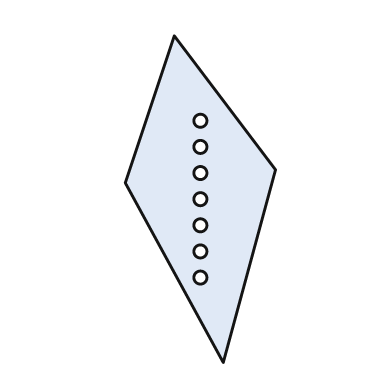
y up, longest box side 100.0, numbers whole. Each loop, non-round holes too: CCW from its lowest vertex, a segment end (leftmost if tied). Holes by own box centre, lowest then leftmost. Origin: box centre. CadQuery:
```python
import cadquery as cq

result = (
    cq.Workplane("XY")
    .moveTo(7.0, -50.0)
    .lineTo(23.0, 9.0)
    .lineTo(-8.0, 50.0)
    .lineTo(-23.0, 5.0)
    .close()
    .moveTo(0.0, -24.0)
    .circle(2.0)
    .moveTo(0.0, -16.0)
    .circle(2.0)
    .moveTo(0.0, -8.0)
    .circle(2.0)
    .moveTo(0.0, 0.0)
    .circle(2.0)
    .moveTo(0.0, 8.0)
    .circle(2.0)
    .moveTo(0.0, 16.0)
    .circle(2.0)
    .moveTo(0.0, 24.0)
    .circle(2.0)
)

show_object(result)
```